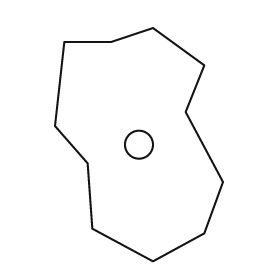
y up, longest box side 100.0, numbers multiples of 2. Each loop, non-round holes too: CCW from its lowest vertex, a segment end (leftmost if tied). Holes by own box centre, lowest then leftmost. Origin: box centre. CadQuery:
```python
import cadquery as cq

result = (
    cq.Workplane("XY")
    .moveTo(6.0, -50.0)
    .lineTo(28.0, -38.0)
    .lineTo(36.0, -16.0)
    .lineTo(20.0, 14.0)
    .lineTo(28.0, 34.0)
    .lineTo(6.0, 50.0)
    .lineTo(-12.0, 44.0)
    .lineTo(-32.0, 44.0)
    .lineTo(-36.0, 8.0)
    .lineTo(-22.0, -8.0)
    .lineTo(-20.0, -36.0)
    .close()
    .moveTo(0.0, 0.0)
    .circle(6.0)
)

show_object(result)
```